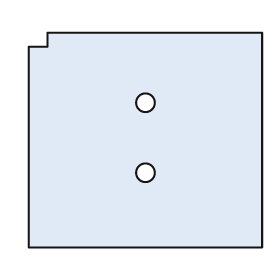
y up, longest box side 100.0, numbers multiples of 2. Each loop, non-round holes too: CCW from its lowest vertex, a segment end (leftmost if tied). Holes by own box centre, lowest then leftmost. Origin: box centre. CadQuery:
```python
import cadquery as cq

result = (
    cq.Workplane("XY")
    .moveTo(-50.0, -46.0)
    .lineTo(50.0, -46.0)
    .lineTo(50.0, 46.0)
    .lineTo(-42.0, 46.0)
    .lineTo(-42.0, 40.0)
    .lineTo(-50.0, 40.0)
    .close()
    .moveTo(0.0, -14.0)
    .circle(4.0)
    .moveTo(0.0, 16.0)
    .circle(4.0)
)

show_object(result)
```